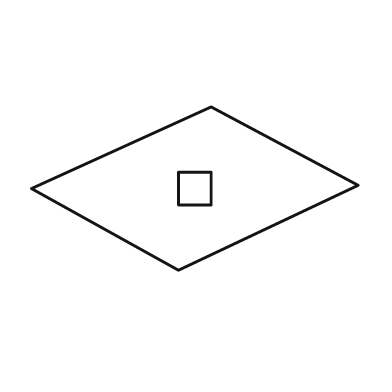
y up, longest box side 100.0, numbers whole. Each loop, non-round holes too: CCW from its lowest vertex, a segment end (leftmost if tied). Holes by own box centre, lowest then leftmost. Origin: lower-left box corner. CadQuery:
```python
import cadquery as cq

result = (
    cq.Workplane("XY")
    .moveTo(45.0, 0.0)
    .lineTo(100.0, 26.0)
    .lineTo(55.0, 50.0)
    .lineTo(0.0, 25.0)
    .close()
    .moveTo(45.0, 20.0)
    .lineTo(55.0, 20.0)
    .lineTo(55.0, 30.0)
    .lineTo(45.0, 30.0)
    .close()
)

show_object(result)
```